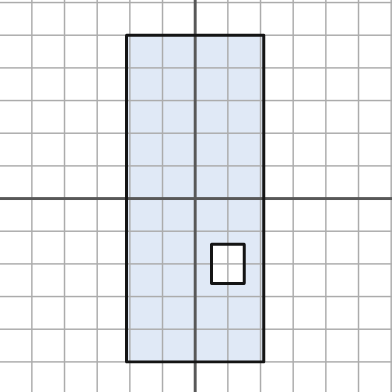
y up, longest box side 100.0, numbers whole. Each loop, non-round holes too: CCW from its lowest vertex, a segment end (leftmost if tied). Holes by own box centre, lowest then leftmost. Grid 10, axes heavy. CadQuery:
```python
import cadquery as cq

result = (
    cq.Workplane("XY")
    .moveTo(-21.0, -50.0)
    .lineTo(21.0, -50.0)
    .lineTo(21.0, 50.0)
    .lineTo(-21.0, 50.0)
    .close()
    .moveTo(5.0, -26.0)
    .lineTo(15.0, -26.0)
    .lineTo(15.0, -14.0)
    .lineTo(5.0, -14.0)
    .close()
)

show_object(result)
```